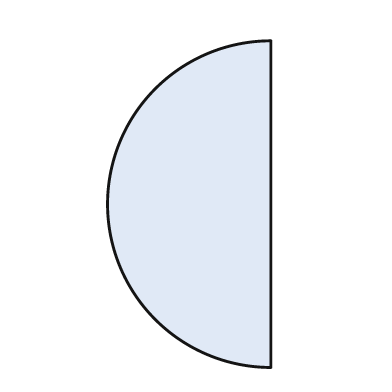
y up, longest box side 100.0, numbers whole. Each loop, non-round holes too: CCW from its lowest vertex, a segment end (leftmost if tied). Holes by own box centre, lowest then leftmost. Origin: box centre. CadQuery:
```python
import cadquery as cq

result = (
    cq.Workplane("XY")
    .moveTo(25.0, -50.0)
    .lineTo(25.0, 50.0)
    .threePointArc((-25.0, 0.0), (25.0, -50.0))
    .close()
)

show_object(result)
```